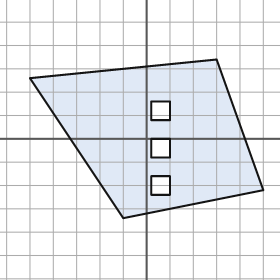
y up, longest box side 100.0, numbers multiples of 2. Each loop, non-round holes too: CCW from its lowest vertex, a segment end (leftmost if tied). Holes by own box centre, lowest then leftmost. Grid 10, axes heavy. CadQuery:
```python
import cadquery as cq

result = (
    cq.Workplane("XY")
    .moveTo(-10.0, -34.0)
    .lineTo(50.0, -22.0)
    .lineTo(30.0, 34.0)
    .lineTo(-50.0, 26.0)
    .close()
    .moveTo(2.0, -24.0)
    .lineTo(10.0, -24.0)
    .lineTo(10.0, -16.0)
    .lineTo(2.0, -16.0)
    .close()
    .moveTo(2.0, -8.0)
    .lineTo(10.0, -8.0)
    .lineTo(10.0, 0.0)
    .lineTo(2.0, 0.0)
    .close()
    .moveTo(2.0, 8.0)
    .lineTo(10.0, 8.0)
    .lineTo(10.0, 16.0)
    .lineTo(2.0, 16.0)
    .close()
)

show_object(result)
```